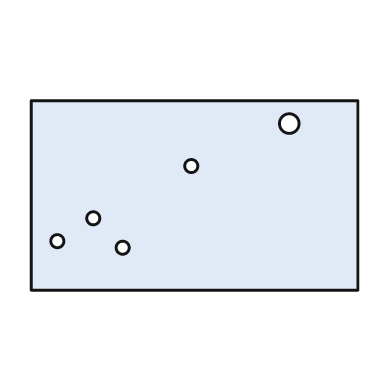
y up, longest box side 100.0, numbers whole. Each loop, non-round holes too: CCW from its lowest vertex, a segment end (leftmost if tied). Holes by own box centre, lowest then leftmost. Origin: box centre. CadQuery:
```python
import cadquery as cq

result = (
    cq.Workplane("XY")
    .moveTo(-50.0, -29.0)
    .lineTo(50.0, -29.0)
    .lineTo(50.0, 29.0)
    .lineTo(-50.0, 29.0)
    .close()
    .moveTo(-22.0, -16.0)
    .circle(2.0)
    .moveTo(-42.0, -14.0)
    .circle(2.0)
    .moveTo(-31.0, -7.0)
    .circle(2.0)
    .moveTo(-1.0, 9.0)
    .circle(2.0)
    .moveTo(29.0, 22.0)
    .circle(3.0)
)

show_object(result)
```